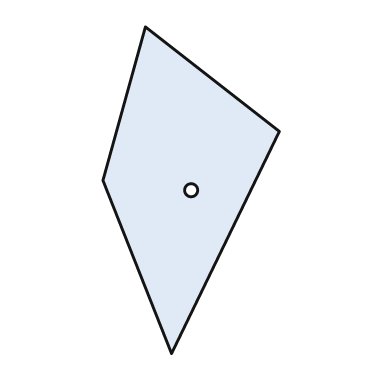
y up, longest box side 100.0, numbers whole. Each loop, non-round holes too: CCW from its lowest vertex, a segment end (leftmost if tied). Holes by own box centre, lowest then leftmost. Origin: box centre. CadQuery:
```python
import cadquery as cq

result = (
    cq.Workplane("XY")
    .moveTo(-6.0, -50.0)
    .lineTo(27.0, 18.0)
    .lineTo(-14.0, 50.0)
    .lineTo(-27.0, 3.0)
    .close()
    .moveTo(0.0, 0.0)
    .circle(2.0)
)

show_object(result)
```